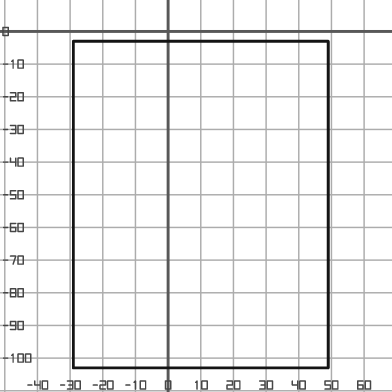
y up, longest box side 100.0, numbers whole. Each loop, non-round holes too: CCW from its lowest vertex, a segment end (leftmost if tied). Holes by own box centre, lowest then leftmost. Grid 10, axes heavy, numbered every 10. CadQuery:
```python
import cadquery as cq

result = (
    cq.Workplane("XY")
    .moveTo(-29.0, -103.0)
    .lineTo(49.0, -103.0)
    .lineTo(49.0, -3.0)
    .lineTo(-29.0, -3.0)
    .close()
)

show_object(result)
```